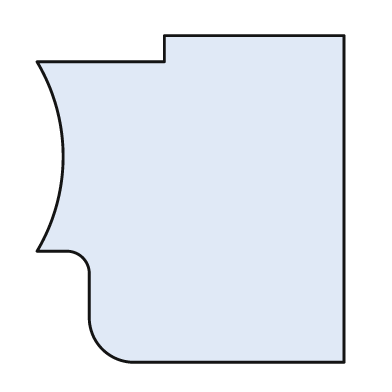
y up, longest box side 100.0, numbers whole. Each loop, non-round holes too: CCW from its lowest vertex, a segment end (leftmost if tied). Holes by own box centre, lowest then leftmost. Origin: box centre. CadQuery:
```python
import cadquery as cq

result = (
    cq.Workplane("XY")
    .moveTo(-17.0, -50.0)
    .lineTo(47.0, -50.0)
    .lineTo(47.0, 50.0)
    .lineTo(-8.0, 50.0)
    .lineTo(-8.0, 42.0)
    .lineTo(-47.0, 42.0)
    .threePointArc((-39.0, 13.0), (-47.0, -16.0))
    .lineTo(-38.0, -16.0)
    .threePointArc((-33.0, -18.0), (-31.0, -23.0))
    .lineTo(-31.0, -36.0)
    .threePointArc((-27.0, -46.0), (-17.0, -50.0))
    .close()
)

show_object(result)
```